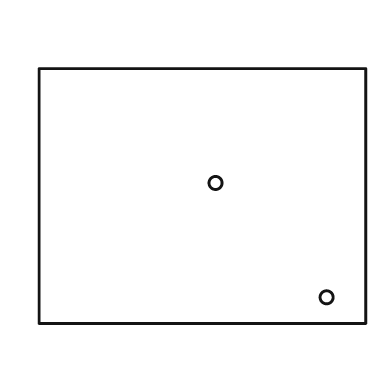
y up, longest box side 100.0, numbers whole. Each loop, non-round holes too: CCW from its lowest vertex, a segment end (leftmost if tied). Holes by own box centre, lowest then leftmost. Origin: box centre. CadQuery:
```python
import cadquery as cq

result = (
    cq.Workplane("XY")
    .moveTo(-50.0, -39.0)
    .lineTo(50.0, -39.0)
    .lineTo(50.0, 39.0)
    .lineTo(-50.0, 39.0)
    .close()
    .moveTo(38.0, -31.0)
    .circle(2.0)
    .moveTo(4.0, 4.0)
    .circle(2.0)
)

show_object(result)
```